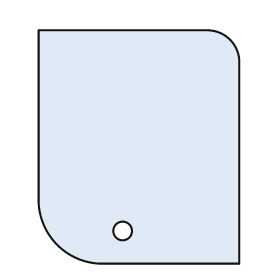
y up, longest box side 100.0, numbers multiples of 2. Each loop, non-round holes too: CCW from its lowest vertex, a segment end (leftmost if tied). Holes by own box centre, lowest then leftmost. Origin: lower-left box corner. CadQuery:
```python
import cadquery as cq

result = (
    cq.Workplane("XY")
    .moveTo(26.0, 0.0)
    .lineTo(86.0, 0.0)
    .lineTo(86.0, 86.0)
    .threePointArc((82.0, 96.0), (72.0, 100.0))
    .lineTo(0.0, 100.0)
    .lineTo(0.0, 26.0)
    .threePointArc((8.0, 8.0), (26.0, 0.0))
    .close()
    .moveTo(36.0, 14.0)
    .circle(4.0)
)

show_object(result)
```